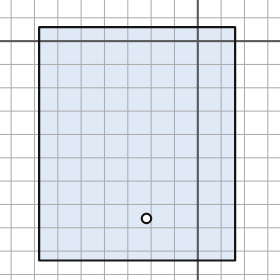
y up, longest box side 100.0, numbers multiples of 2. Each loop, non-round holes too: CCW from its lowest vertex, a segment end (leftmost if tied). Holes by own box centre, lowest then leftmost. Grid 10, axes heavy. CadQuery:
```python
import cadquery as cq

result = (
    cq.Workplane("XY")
    .moveTo(-68.0, -94.0)
    .lineTo(16.0, -94.0)
    .lineTo(16.0, 6.0)
    .lineTo(-68.0, 6.0)
    .close()
    .moveTo(-22.0, -76.0)
    .circle(2.0)
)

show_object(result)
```